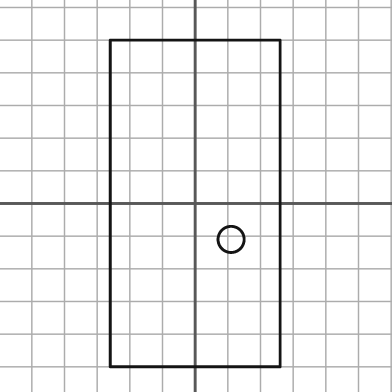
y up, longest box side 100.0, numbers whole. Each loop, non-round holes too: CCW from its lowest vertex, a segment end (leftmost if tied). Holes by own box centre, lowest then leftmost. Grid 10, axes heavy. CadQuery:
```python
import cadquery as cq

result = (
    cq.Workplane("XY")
    .moveTo(-26.0, -50.0)
    .lineTo(26.0, -50.0)
    .lineTo(26.0, 50.0)
    .lineTo(-26.0, 50.0)
    .close()
    .moveTo(11.0, -11.0)
    .circle(4.0)
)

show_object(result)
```